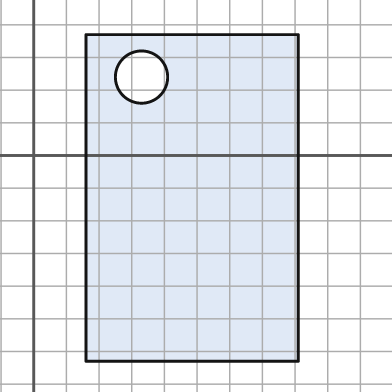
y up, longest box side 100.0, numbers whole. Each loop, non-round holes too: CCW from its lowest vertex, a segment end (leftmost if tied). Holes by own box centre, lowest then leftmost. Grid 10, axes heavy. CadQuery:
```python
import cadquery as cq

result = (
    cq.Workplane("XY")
    .moveTo(16.0, -63.0)
    .lineTo(81.0, -63.0)
    .lineTo(81.0, 37.0)
    .lineTo(16.0, 37.0)
    .close()
    .moveTo(33.0, 24.0)
    .circle(8.0)
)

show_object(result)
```